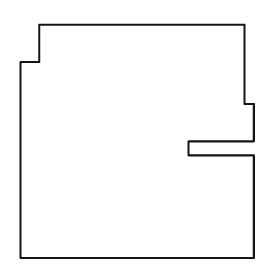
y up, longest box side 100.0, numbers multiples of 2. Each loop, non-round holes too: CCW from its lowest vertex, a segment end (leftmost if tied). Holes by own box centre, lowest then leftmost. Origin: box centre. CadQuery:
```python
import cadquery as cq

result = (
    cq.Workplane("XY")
    .moveTo(-50.0, -50.0)
    .lineTo(50.0, -50.0)
    .lineTo(50.0, -6.0)
    .lineTo(22.0, -6.0)
    .lineTo(22.0, 0.0)
    .lineTo(50.0, 0.0)
    .lineTo(50.0, 16.0)
    .lineTo(46.0, 16.0)
    .lineTo(46.0, 50.0)
    .lineTo(-42.0, 50.0)
    .lineTo(-42.0, 34.0)
    .lineTo(-50.0, 34.0)
    .close()
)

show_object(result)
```